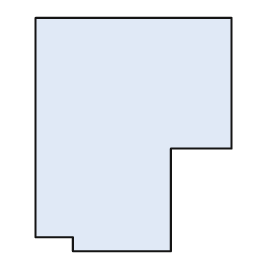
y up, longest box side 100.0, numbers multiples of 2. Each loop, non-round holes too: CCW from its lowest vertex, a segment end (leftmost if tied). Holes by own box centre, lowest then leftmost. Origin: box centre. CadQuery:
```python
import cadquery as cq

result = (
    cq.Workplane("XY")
    .moveTo(-26.0, -50.0)
    .lineTo(16.0, -50.0)
    .lineTo(16.0, -6.0)
    .lineTo(42.0, -6.0)
    .lineTo(42.0, 50.0)
    .lineTo(-42.0, 50.0)
    .lineTo(-42.0, -44.0)
    .lineTo(-26.0, -44.0)
    .close()
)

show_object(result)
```